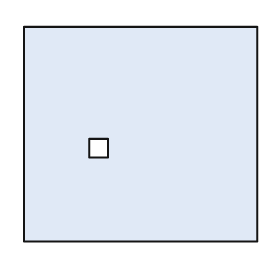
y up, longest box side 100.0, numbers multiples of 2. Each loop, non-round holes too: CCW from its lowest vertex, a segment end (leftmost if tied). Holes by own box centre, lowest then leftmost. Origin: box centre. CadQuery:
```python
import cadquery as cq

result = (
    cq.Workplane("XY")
    .moveTo(-50.0, -46.0)
    .lineTo(50.0, -46.0)
    .lineTo(50.0, 46.0)
    .lineTo(-50.0, 46.0)
    .close()
    .moveTo(-22.0, -10.0)
    .lineTo(-14.0, -10.0)
    .lineTo(-14.0, -2.0)
    .lineTo(-22.0, -2.0)
    .close()
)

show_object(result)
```